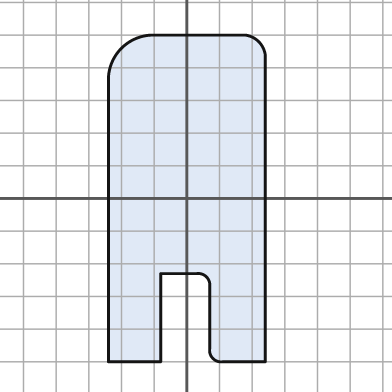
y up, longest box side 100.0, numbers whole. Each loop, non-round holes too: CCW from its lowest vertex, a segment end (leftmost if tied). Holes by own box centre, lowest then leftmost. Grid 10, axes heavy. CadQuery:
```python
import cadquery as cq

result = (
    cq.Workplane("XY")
    .moveTo(-24.0, -50.0)
    .lineTo(-8.0, -50.0)
    .lineTo(-8.0, -23.0)
    .lineTo(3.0, -23.0)
    .threePointArc((6.0, -24.0), (7.0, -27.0))
    .lineTo(7.0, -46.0)
    .threePointArc((8.0, -49.0), (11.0, -50.0))
    .lineTo(24.0, -50.0)
    .lineTo(24.0, 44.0)
    .threePointArc((22.0, 48.0), (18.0, 50.0))
    .lineTo(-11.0, 50.0)
    .threePointArc((-20.0, 46.0), (-24.0, 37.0))
    .close()
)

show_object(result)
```